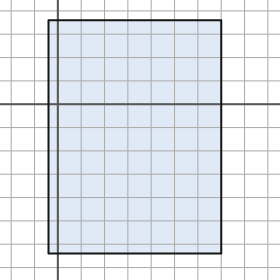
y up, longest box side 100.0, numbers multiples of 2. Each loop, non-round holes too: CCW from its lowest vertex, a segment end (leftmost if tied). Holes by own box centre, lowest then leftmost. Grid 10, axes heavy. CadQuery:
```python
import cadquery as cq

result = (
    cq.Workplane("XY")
    .moveTo(-4.0, -64.0)
    .lineTo(70.0, -64.0)
    .lineTo(70.0, 36.0)
    .lineTo(-4.0, 36.0)
    .close()
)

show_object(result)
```